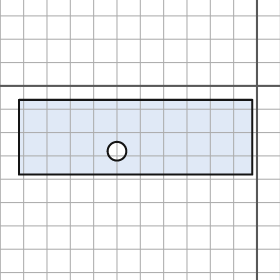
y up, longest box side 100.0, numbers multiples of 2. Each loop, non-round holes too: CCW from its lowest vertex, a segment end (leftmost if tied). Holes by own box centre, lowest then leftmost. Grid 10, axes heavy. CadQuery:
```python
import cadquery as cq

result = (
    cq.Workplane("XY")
    .moveTo(-102.0, -38.0)
    .lineTo(-2.0, -38.0)
    .lineTo(-2.0, -6.0)
    .lineTo(-102.0, -6.0)
    .close()
    .moveTo(-60.0, -28.0)
    .circle(4.0)
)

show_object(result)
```